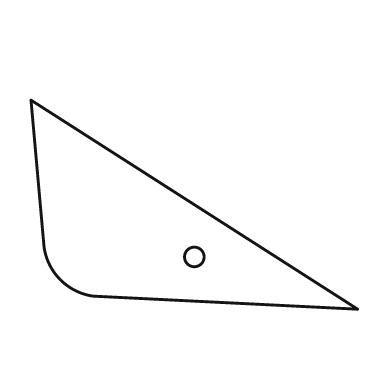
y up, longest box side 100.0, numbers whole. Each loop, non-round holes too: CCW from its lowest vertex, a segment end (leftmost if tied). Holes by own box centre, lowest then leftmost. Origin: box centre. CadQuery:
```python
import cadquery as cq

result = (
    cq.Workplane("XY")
    .moveTo(50.0, -32.0)
    .lineTo(-50.0, 32.0)
    .lineTo(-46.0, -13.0)
    .threePointArc((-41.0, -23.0), (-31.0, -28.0))
    .close()
    .moveTo(0.0, -16.0)
    .circle(3.0)
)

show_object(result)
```